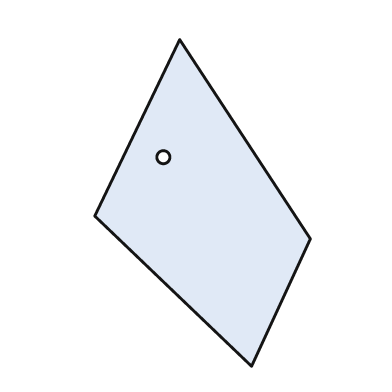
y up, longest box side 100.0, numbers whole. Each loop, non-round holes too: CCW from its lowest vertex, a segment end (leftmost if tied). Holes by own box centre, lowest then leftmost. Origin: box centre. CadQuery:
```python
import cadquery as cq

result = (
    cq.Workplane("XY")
    .moveTo(15.0, -50.0)
    .lineTo(33.0, -11.0)
    .lineTo(-7.0, 50.0)
    .lineTo(-33.0, -4.0)
    .close()
    .moveTo(-12.0, 14.0)
    .circle(2.0)
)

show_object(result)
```